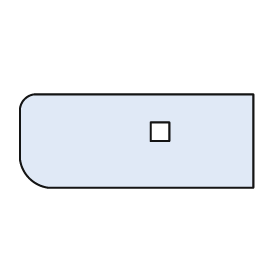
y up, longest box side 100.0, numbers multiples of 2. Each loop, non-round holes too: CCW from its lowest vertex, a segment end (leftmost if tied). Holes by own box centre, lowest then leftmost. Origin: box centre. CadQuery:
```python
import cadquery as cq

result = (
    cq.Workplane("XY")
    .moveTo(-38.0, -20.0)
    .lineTo(50.0, -20.0)
    .lineTo(50.0, 20.0)
    .lineTo(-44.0, 20.0)
    .threePointArc((-48.0, 18.0), (-50.0, 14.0))
    .lineTo(-50.0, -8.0)
    .threePointArc((-46.0, -16.0), (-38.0, -20.0))
    .close()
    .moveTo(6.0, 0.0)
    .lineTo(14.0, 0.0)
    .lineTo(14.0, 8.0)
    .lineTo(6.0, 8.0)
    .close()
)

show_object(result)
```